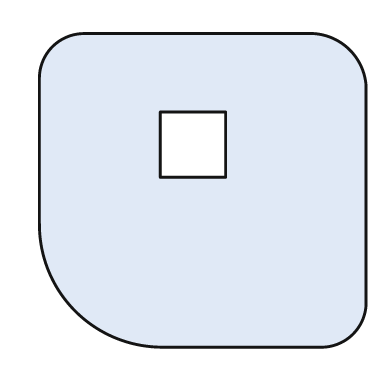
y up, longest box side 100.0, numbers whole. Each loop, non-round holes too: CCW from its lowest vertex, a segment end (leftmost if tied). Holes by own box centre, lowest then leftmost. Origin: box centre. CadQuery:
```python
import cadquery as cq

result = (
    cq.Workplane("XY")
    .moveTo(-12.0, -48.0)
    .lineTo(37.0, -48.0)
    .threePointArc((46.0, -44.0), (50.0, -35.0))
    .lineTo(50.0, 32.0)
    .threePointArc((45.0, 43.0), (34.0, 48.0))
    .lineTo(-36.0, 48.0)
    .threePointArc((-46.0, 44.0), (-50.0, 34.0))
    .lineTo(-50.0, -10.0)
    .threePointArc((-39.0, -37.0), (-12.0, -48.0))
    .close()
    .moveTo(-13.0, 4.0)
    .lineTo(7.0, 4.0)
    .lineTo(7.0, 24.0)
    .lineTo(-13.0, 24.0)
    .close()
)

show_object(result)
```